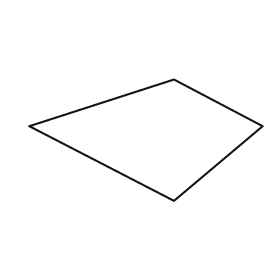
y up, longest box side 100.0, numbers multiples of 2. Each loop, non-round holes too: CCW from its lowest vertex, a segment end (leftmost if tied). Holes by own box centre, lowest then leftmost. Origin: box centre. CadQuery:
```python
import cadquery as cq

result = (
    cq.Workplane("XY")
    .moveTo(12.0, -26.0)
    .lineTo(50.0, 6.0)
    .lineTo(12.0, 26.0)
    .lineTo(-50.0, 6.0)
    .close()
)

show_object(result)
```